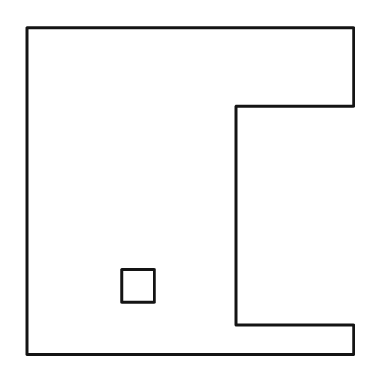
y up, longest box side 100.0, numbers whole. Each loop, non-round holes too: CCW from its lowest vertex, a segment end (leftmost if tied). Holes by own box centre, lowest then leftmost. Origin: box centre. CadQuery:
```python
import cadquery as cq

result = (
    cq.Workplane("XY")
    .moveTo(-50.0, -50.0)
    .lineTo(50.0, -50.0)
    .lineTo(50.0, -41.0)
    .lineTo(14.0, -41.0)
    .lineTo(14.0, 26.0)
    .lineTo(50.0, 26.0)
    .lineTo(50.0, 50.0)
    .lineTo(-50.0, 50.0)
    .close()
    .moveTo(-21.0, -34.0)
    .lineTo(-11.0, -34.0)
    .lineTo(-11.0, -24.0)
    .lineTo(-21.0, -24.0)
    .close()
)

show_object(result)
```